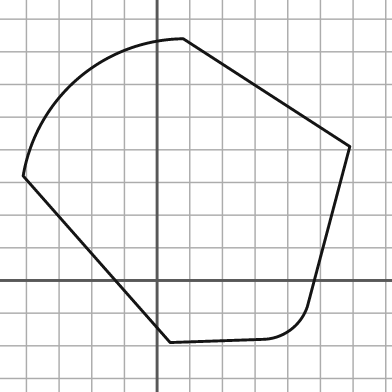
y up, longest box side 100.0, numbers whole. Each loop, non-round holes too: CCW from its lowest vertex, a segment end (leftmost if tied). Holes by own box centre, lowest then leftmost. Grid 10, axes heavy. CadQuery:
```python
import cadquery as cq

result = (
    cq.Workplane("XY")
    .moveTo(4.0, -19.0)
    .lineTo(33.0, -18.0)
    .threePointArc((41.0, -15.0), (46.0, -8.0))
    .lineTo(59.0, 41.0)
    .lineTo(8.0, 74.0)
    .threePointArc((-24.0, 62.0), (-41.0, 32.0))
    .close()
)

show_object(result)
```